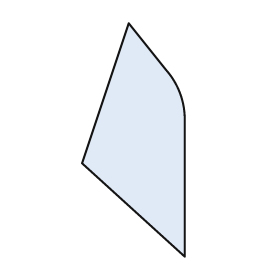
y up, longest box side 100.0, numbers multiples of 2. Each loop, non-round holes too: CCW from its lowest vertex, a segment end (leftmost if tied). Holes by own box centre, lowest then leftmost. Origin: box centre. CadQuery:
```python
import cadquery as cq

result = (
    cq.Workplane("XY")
    .moveTo(22.0, -50.0)
    .lineTo(22.0, 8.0)
    .threePointArc((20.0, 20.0), (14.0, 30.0))
    .lineTo(-2.0, 50.0)
    .lineTo(-22.0, -10.0)
    .close()
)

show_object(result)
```